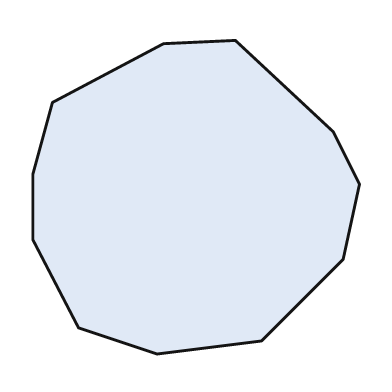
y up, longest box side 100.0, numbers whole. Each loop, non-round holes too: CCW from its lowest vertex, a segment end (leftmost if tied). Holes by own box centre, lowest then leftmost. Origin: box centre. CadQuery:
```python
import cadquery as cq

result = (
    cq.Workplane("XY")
    .moveTo(-12.0, -48.0)
    .lineTo(20.0, -44.0)
    .lineTo(45.0, -19.0)
    .lineTo(50.0, 4.0)
    .lineTo(42.0, 20.0)
    .lineTo(12.0, 48.0)
    .lineTo(-10.0, 47.0)
    .lineTo(-44.0, 29.0)
    .lineTo(-50.0, 7.0)
    .lineTo(-50.0, -13.0)
    .lineTo(-36.0, -40.0)
    .close()
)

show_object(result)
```